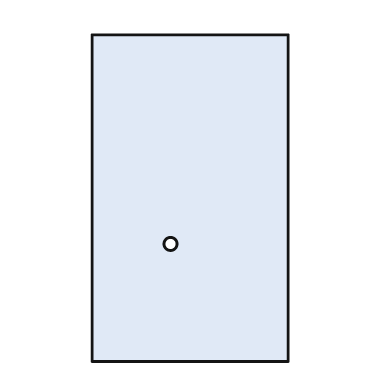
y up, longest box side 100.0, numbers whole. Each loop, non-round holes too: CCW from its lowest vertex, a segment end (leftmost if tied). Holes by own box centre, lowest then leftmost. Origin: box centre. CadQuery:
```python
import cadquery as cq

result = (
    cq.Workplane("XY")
    .moveTo(-30.0, -50.0)
    .lineTo(30.0, -50.0)
    .lineTo(30.0, 50.0)
    .lineTo(-30.0, 50.0)
    .close()
    .moveTo(-6.0, -14.0)
    .circle(2.0)
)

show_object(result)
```